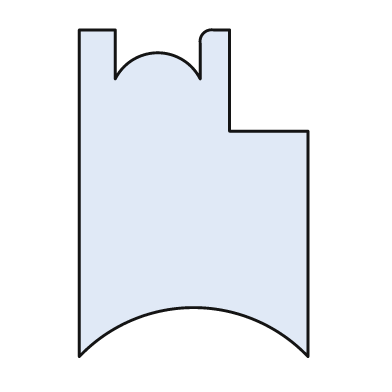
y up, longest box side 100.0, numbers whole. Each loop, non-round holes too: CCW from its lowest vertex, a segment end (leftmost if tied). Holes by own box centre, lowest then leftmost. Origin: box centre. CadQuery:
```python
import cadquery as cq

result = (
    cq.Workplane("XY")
    .moveTo(-35.0, -50.0)
    .threePointArc((0.0, -35.0), (35.0, -50.0))
    .lineTo(35.0, 19.0)
    .lineTo(11.0, 19.0)
    .lineTo(11.0, 50.0)
    .lineTo(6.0, 50.0)
    .threePointArc((3.0, 49.0), (2.0, 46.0))
    .lineTo(2.0, 35.0)
    .threePointArc((-11.0, 43.0), (-24.0, 35.0))
    .lineTo(-24.0, 50.0)
    .lineTo(-35.0, 50.0)
    .close()
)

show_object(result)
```